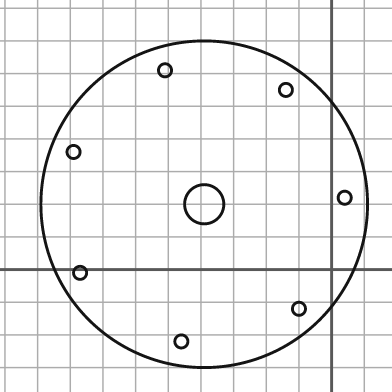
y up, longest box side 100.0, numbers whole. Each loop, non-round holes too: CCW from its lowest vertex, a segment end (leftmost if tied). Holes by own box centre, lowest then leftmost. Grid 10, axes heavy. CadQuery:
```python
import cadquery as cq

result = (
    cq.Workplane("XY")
    .moveTo(-39.0, 20.0)
    .circle(50.0)
    .moveTo(-46.0, -22.0)
    .circle(2.0)
    .moveTo(-10.0, -12.0)
    .circle(2.0)
    .moveTo(-77.0, -1.0)
    .circle(2.0)
    .moveTo(-39.0, 20.0)
    .circle(6.0)
    .moveTo(4.0, 22.0)
    .circle(2.0)
    .moveTo(-79.0, 36.0)
    .circle(2.0)
    .moveTo(-14.0, 55.0)
    .circle(2.0)
    .moveTo(-51.0, 61.0)
    .circle(2.0)
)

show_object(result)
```